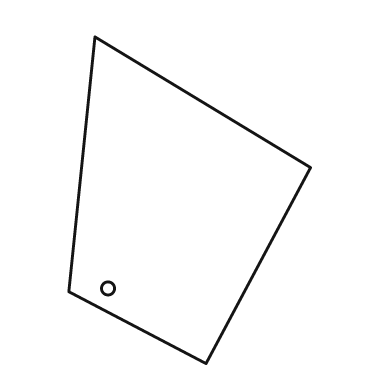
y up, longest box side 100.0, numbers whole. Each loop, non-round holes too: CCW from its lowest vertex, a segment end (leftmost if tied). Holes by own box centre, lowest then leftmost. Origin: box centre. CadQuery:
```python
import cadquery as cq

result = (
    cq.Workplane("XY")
    .moveTo(5.0, -50.0)
    .lineTo(37.0, 10.0)
    .lineTo(-29.0, 50.0)
    .lineTo(-37.0, -28.0)
    .close()
    .moveTo(-25.0, -27.0)
    .circle(2.0)
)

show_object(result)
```